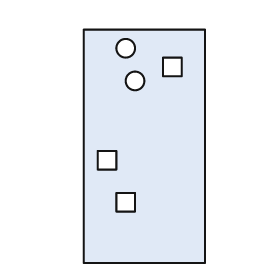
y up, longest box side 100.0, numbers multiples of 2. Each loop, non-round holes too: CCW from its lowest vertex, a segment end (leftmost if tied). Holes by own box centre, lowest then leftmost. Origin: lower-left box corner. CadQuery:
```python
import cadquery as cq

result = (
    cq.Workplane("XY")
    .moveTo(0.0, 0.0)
    .lineTo(52.0, 0.0)
    .lineTo(52.0, 100.0)
    .lineTo(0.0, 100.0)
    .close()
    .moveTo(14.0, 22.0)
    .lineTo(22.0, 22.0)
    .lineTo(22.0, 30.0)
    .lineTo(14.0, 30.0)
    .close()
    .moveTo(6.0, 40.0)
    .lineTo(14.0, 40.0)
    .lineTo(14.0, 48.0)
    .lineTo(6.0, 48.0)
    .close()
    .moveTo(22.0, 78.0)
    .circle(4.0)
    .moveTo(34.0, 80.0)
    .lineTo(42.0, 80.0)
    .lineTo(42.0, 88.0)
    .lineTo(34.0, 88.0)
    .close()
    .moveTo(18.0, 92.0)
    .circle(4.0)
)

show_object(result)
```